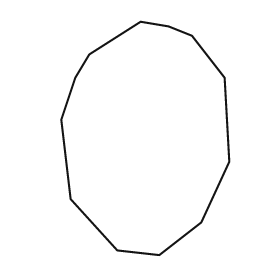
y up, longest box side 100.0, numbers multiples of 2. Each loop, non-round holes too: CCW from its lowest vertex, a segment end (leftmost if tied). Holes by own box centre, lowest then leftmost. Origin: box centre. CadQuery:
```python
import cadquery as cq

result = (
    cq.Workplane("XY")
    .moveTo(6.0, -50.0)
    .lineTo(24.0, -36.0)
    .lineTo(36.0, -10.0)
    .lineTo(34.0, 26.0)
    .lineTo(20.0, 44.0)
    .lineTo(10.0, 48.0)
    .lineTo(-2.0, 50.0)
    .lineTo(-24.0, 36.0)
    .lineTo(-30.0, 26.0)
    .lineTo(-36.0, 8.0)
    .lineTo(-32.0, -26.0)
    .lineTo(-12.0, -48.0)
    .close()
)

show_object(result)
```